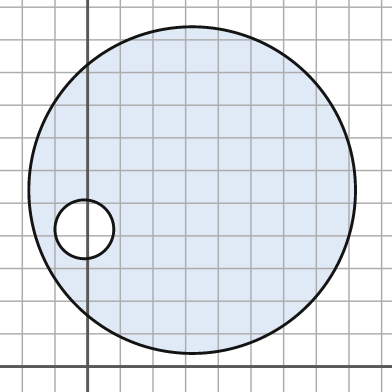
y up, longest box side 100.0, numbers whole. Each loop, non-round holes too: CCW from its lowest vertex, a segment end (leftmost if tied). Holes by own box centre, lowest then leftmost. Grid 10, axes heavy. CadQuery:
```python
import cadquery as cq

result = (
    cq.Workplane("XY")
    .moveTo(32.0, 54.0)
    .circle(50.0)
    .moveTo(-1.0, 42.0)
    .circle(9.0)
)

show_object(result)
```